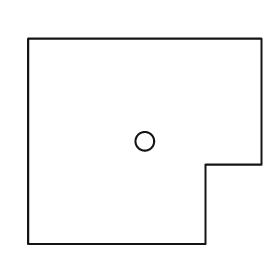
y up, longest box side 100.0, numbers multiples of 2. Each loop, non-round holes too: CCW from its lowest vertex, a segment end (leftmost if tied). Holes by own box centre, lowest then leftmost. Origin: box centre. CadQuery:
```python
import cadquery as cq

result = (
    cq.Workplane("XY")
    .moveTo(-50.0, -44.0)
    .lineTo(26.0, -44.0)
    .lineTo(26.0, -10.0)
    .lineTo(50.0, -10.0)
    .lineTo(50.0, 44.0)
    .lineTo(-50.0, 44.0)
    .close()
    .moveTo(0.0, 0.0)
    .circle(4.0)
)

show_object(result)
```